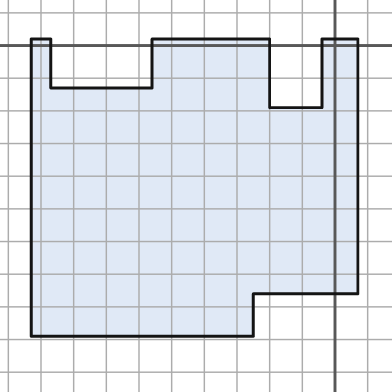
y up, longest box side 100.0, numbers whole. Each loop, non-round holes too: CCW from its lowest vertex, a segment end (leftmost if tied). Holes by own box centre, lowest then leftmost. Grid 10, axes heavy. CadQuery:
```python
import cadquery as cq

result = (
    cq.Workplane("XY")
    .moveTo(-93.0, -89.0)
    .lineTo(-25.0, -89.0)
    .lineTo(-25.0, -76.0)
    .lineTo(7.0, -76.0)
    .lineTo(7.0, 2.0)
    .lineTo(-4.0, 2.0)
    .lineTo(-4.0, -19.0)
    .lineTo(-20.0, -19.0)
    .lineTo(-20.0, 2.0)
    .lineTo(-56.0, 2.0)
    .lineTo(-56.0, -13.0)
    .lineTo(-87.0, -13.0)
    .lineTo(-87.0, 2.0)
    .lineTo(-93.0, 2.0)
    .close()
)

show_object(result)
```